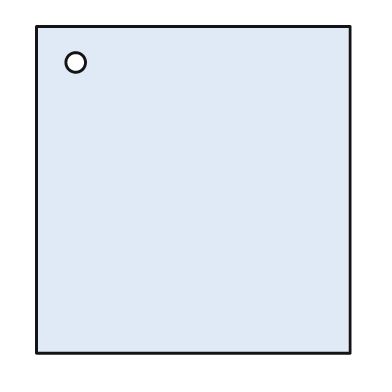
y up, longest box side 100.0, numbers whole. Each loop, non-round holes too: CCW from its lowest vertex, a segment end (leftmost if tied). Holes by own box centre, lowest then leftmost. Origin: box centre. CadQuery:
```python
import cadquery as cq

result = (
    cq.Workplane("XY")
    .moveTo(-48.0, -50.0)
    .lineTo(48.0, -50.0)
    .lineTo(48.0, 50.0)
    .lineTo(-48.0, 50.0)
    .close()
    .moveTo(-36.0, 39.0)
    .circle(3.0)
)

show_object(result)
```